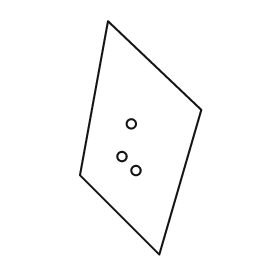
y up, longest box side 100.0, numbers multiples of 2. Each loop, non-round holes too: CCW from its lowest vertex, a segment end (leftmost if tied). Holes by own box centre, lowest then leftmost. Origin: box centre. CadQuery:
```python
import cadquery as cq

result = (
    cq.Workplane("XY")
    .moveTo(8.0, -50.0)
    .lineTo(26.0, 12.0)
    .lineTo(-14.0, 50.0)
    .lineTo(-26.0, -16.0)
    .close()
    .moveTo(-2.0, -14.0)
    .circle(2.0)
    .moveTo(-8.0, -8.0)
    .circle(2.0)
    .moveTo(-4.0, 6.0)
    .circle(2.0)
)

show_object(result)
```